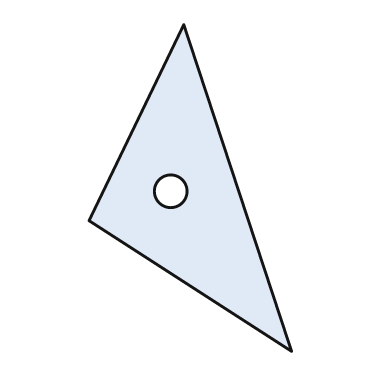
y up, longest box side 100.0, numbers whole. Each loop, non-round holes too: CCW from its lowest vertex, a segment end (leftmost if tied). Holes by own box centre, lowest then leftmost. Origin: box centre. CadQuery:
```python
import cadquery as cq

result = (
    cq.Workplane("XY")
    .moveTo(31.0, -50.0)
    .lineTo(-2.0, 50.0)
    .lineTo(-31.0, -10.0)
    .close()
    .moveTo(-6.0, -1.0)
    .circle(5.0)
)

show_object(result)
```